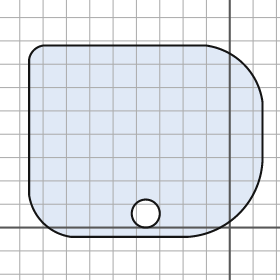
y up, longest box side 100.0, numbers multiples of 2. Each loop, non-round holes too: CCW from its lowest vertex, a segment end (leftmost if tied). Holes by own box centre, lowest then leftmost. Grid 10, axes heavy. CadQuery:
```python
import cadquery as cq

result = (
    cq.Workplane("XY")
    .moveTo(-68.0, -4.0)
    .lineTo(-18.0, -4.0)
    .threePointArc((4.0, 6.0), (14.0, 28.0))
    .lineTo(14.0, 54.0)
    .threePointArc((6.0, 70.0), (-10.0, 78.0))
    .lineTo(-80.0, 78.0)
    .threePointArc((-84.0, 76.0), (-86.0, 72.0))
    .lineTo(-86.0, 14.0)
    .threePointArc((-80.0, 2.0), (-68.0, -4.0))
    .close()
    .moveTo(-36.0, 6.0)
    .circle(6.0)
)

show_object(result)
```